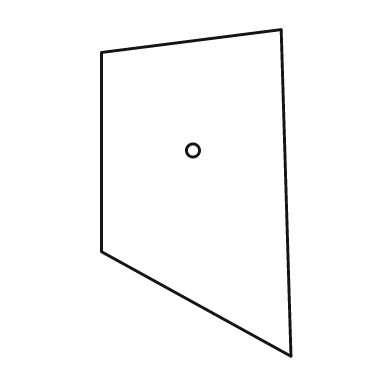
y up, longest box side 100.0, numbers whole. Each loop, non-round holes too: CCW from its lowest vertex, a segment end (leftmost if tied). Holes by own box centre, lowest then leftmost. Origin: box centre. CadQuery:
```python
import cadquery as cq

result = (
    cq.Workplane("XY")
    .moveTo(29.0, -50.0)
    .lineTo(26.0, 50.0)
    .lineTo(-29.0, 43.0)
    .lineTo(-29.0, -18.0)
    .close()
    .moveTo(-1.0, 13.0)
    .circle(2.0)
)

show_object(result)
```